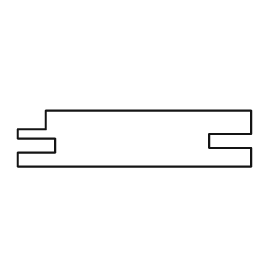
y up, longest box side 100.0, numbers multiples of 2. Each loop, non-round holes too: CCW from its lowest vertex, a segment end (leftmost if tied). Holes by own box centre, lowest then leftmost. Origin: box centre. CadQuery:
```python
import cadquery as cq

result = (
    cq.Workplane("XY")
    .moveTo(-50.0, -12.0)
    .lineTo(50.0, -12.0)
    .lineTo(50.0, -4.0)
    .lineTo(32.0, -4.0)
    .lineTo(32.0, 2.0)
    .lineTo(50.0, 2.0)
    .lineTo(50.0, 12.0)
    .lineTo(-38.0, 12.0)
    .lineTo(-38.0, 4.0)
    .lineTo(-50.0, 4.0)
    .lineTo(-50.0, 0.0)
    .lineTo(-34.0, 0.0)
    .lineTo(-34.0, -6.0)
    .lineTo(-50.0, -6.0)
    .close()
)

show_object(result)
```